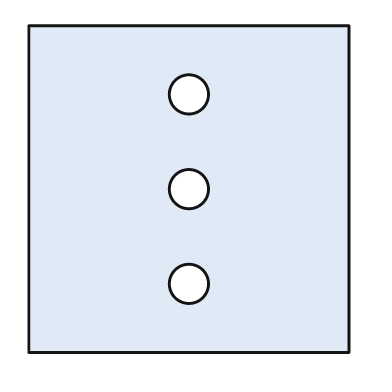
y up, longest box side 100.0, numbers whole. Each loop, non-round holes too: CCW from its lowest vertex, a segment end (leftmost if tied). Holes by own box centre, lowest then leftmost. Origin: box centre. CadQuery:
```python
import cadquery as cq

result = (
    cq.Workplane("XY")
    .moveTo(-49.0, -50.0)
    .lineTo(49.0, -50.0)
    .lineTo(49.0, 50.0)
    .lineTo(-49.0, 50.0)
    .close()
    .moveTo(0.0, -29.0)
    .circle(6.0)
    .moveTo(0.0, 0.0)
    .circle(6.0)
    .moveTo(0.0, 29.0)
    .circle(6.0)
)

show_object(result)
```